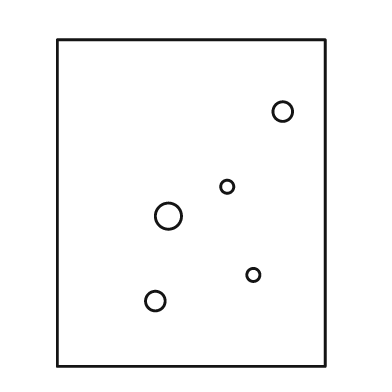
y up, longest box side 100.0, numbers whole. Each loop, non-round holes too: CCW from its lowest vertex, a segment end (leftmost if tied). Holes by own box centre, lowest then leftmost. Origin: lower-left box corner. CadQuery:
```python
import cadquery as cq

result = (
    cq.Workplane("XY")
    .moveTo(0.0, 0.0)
    .lineTo(82.0, 0.0)
    .lineTo(82.0, 100.0)
    .lineTo(0.0, 100.0)
    .close()
    .moveTo(30.0, 20.0)
    .circle(3.0)
    .moveTo(60.0, 28.0)
    .circle(2.0)
    .moveTo(34.0, 46.0)
    .circle(4.0)
    .moveTo(52.0, 55.0)
    .circle(2.0)
    .moveTo(69.0, 78.0)
    .circle(3.0)
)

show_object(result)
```